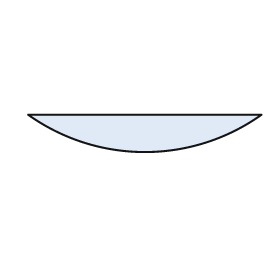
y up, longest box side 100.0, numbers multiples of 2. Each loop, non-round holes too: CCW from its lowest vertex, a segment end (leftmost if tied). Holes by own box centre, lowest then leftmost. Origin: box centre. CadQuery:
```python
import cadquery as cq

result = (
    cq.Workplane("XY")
    .moveTo(-50.0, 8.0)
    .threePointArc((0.0, -8.0), (50.0, 8.0))
    .close()
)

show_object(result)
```